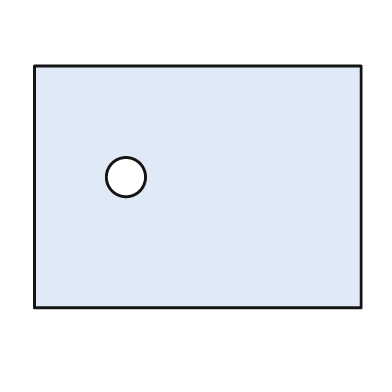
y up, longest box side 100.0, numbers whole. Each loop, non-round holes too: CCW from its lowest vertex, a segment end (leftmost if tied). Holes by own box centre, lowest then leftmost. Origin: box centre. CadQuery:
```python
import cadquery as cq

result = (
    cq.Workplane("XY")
    .moveTo(-50.0, -37.0)
    .lineTo(50.0, -37.0)
    .lineTo(50.0, 37.0)
    .lineTo(-50.0, 37.0)
    .close()
    .moveTo(-22.0, 3.0)
    .circle(6.0)
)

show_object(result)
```